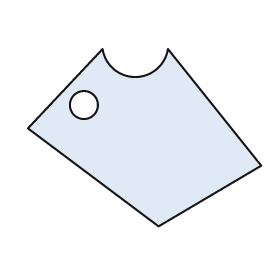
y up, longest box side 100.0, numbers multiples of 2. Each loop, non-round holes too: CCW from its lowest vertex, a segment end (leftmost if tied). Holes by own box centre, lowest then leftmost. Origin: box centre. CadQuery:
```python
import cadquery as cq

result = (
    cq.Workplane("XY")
    .moveTo(6.0, -38.0)
    .lineTo(50.0, -12.0)
    .lineTo(10.0, 38.0)
    .threePointArc((-4.0, 26.0), (-18.0, 38.0))
    .lineTo(-50.0, 4.0)
    .close()
    .moveTo(-26.0, 14.0)
    .circle(6.0)
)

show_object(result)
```